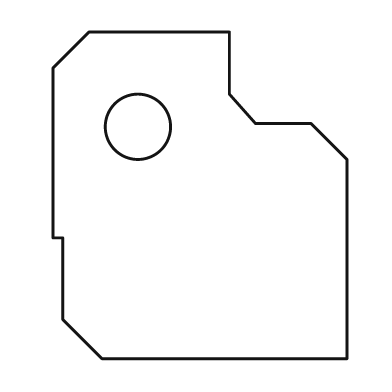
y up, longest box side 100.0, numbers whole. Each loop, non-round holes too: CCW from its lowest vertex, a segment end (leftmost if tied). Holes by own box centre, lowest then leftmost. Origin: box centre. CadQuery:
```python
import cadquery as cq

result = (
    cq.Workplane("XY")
    .moveTo(-30.0, -50.0)
    .lineTo(45.0, -50.0)
    .lineTo(45.0, 11.0)
    .lineTo(34.0, 22.0)
    .lineTo(17.0, 22.0)
    .lineTo(9.0, 31.0)
    .lineTo(9.0, 50.0)
    .lineTo(-34.0, 50.0)
    .lineTo(-45.0, 39.0)
    .lineTo(-45.0, -13.0)
    .lineTo(-42.0, -13.0)
    .lineTo(-42.0, -38.0)
    .close()
    .moveTo(-19.0, 21.0)
    .circle(10.0)
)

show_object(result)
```